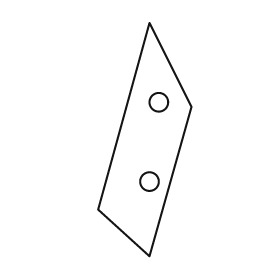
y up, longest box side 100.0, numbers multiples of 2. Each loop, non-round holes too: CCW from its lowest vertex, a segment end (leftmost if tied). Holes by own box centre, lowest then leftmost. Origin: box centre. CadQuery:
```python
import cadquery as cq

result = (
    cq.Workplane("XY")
    .moveTo(2.0, -50.0)
    .lineTo(20.0, 14.0)
    .lineTo(2.0, 50.0)
    .lineTo(-20.0, -30.0)
    .close()
    .moveTo(2.0, -18.0)
    .circle(4.0)
    .moveTo(6.0, 16.0)
    .circle(4.0)
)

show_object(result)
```